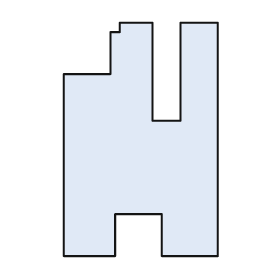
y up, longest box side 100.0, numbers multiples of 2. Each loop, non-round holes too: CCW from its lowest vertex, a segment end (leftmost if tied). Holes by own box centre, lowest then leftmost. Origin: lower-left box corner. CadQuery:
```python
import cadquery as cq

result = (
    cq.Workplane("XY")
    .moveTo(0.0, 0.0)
    .lineTo(22.0, 0.0)
    .lineTo(22.0, 18.0)
    .lineTo(42.0, 18.0)
    .lineTo(42.0, 0.0)
    .lineTo(66.0, 0.0)
    .lineTo(66.0, 100.0)
    .lineTo(50.0, 100.0)
    .lineTo(50.0, 58.0)
    .lineTo(38.0, 58.0)
    .lineTo(38.0, 100.0)
    .lineTo(24.0, 100.0)
    .lineTo(24.0, 96.0)
    .lineTo(20.0, 96.0)
    .lineTo(20.0, 78.0)
    .lineTo(0.0, 78.0)
    .close()
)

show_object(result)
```